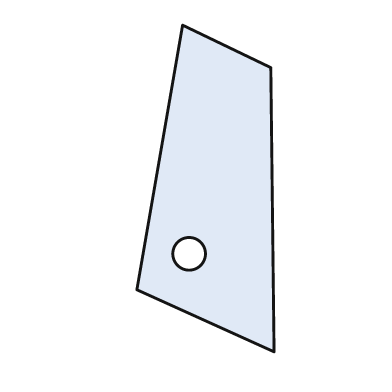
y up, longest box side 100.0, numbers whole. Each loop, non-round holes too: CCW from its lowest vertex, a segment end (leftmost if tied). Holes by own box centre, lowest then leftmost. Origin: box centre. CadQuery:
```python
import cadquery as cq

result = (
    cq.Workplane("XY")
    .moveTo(21.0, -50.0)
    .lineTo(20.0, 37.0)
    .lineTo(-7.0, 50.0)
    .lineTo(-21.0, -31.0)
    .close()
    .moveTo(-5.0, -20.0)
    .circle(5.0)
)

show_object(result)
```